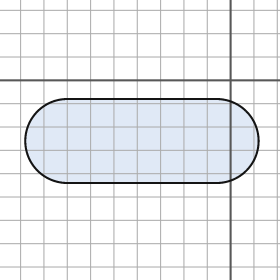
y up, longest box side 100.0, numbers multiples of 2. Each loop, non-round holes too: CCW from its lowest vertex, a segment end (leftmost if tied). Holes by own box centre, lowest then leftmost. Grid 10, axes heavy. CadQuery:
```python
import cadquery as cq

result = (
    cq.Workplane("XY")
    .moveTo(-70.0, -44.0)
    .lineTo(-6.0, -44.0)
    .threePointArc((12.0, -26.0), (-6.0, -8.0))
    .lineTo(-70.0, -8.0)
    .threePointArc((-88.0, -26.0), (-70.0, -44.0))
    .close()
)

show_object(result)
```